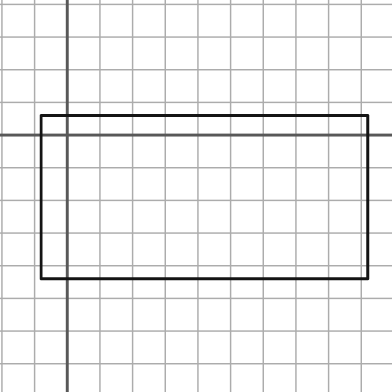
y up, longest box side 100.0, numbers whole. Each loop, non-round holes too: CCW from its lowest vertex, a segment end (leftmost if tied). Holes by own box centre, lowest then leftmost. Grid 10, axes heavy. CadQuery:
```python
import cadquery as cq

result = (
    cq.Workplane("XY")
    .moveTo(-8.0, -44.0)
    .lineTo(92.0, -44.0)
    .lineTo(92.0, 6.0)
    .lineTo(-8.0, 6.0)
    .close()
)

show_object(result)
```